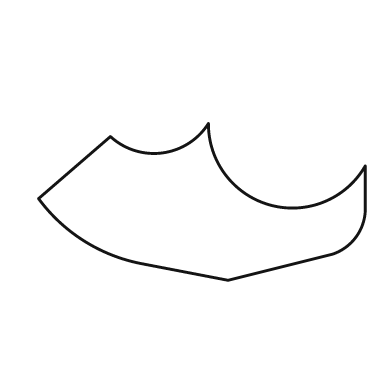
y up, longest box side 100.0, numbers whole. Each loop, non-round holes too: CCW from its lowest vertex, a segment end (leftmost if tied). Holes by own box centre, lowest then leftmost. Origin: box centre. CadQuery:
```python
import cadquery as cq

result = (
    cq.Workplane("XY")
    .moveTo(8.0, -24.0)
    .lineTo(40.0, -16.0)
    .threePointArc((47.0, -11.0), (50.0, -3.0))
    .lineTo(50.0, 11.0)
    .threePointArc((21.0, -1.0), (2.0, 24.0))
    .threePointArc((-12.0, 15.0), (-28.0, 20.0))
    .lineTo(-50.0, 1.0)
    .threePointArc((-36.0, -12.0), (-18.0, -19.0))
    .close()
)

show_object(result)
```